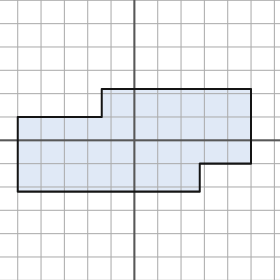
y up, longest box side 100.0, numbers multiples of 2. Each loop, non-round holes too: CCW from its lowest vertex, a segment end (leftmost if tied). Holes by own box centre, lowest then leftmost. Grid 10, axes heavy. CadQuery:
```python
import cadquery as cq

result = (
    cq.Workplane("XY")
    .moveTo(-50.0, -22.0)
    .lineTo(28.0, -22.0)
    .lineTo(28.0, -10.0)
    .lineTo(50.0, -10.0)
    .lineTo(50.0, 22.0)
    .lineTo(-14.0, 22.0)
    .lineTo(-14.0, 10.0)
    .lineTo(-50.0, 10.0)
    .close()
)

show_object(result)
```